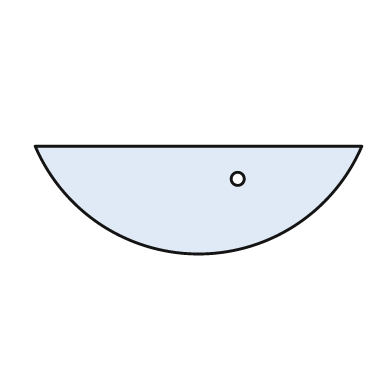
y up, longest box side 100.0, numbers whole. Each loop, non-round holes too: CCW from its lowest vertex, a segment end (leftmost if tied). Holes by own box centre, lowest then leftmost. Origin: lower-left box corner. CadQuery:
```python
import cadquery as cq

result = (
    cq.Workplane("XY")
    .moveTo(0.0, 33.0)
    .threePointArc((50.0, 0.0), (100.0, 33.0))
    .close()
    .moveTo(62.0, 23.0)
    .circle(2.0)
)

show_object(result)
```